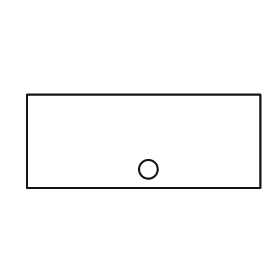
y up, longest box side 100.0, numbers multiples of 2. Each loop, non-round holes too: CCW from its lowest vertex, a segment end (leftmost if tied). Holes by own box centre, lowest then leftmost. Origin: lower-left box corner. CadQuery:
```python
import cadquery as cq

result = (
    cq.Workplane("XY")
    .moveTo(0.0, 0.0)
    .lineTo(100.0, 0.0)
    .lineTo(100.0, 40.0)
    .lineTo(0.0, 40.0)
    .close()
    .moveTo(52.0, 8.0)
    .circle(4.0)
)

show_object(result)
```